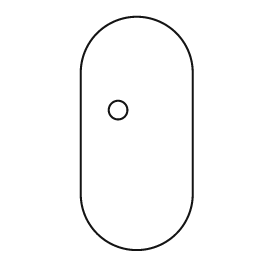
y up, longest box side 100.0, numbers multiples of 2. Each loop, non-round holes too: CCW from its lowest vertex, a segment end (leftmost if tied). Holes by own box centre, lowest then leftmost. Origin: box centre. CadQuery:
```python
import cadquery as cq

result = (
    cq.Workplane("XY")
    .moveTo(-24.0, -26.0)
    .threePointArc((0.0, -50.0), (24.0, -26.0))
    .lineTo(24.0, 26.0)
    .threePointArc((0.0, 50.0), (-24.0, 26.0))
    .close()
    .moveTo(-8.0, 10.0)
    .circle(4.0)
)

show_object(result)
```